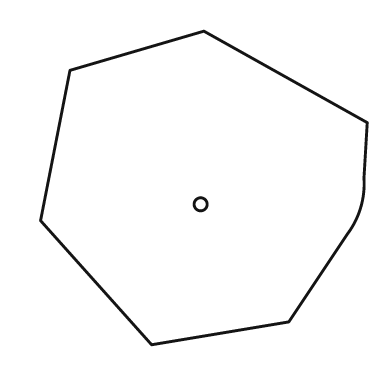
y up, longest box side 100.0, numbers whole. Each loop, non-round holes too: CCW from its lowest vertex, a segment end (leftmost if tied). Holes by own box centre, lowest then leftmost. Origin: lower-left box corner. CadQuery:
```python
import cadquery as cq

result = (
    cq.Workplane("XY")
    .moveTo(34.0, 0.0)
    .lineTo(76.0, 7.0)
    .lineTo(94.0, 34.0)
    .threePointArc((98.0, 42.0), (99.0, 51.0))
    .lineTo(100.0, 68.0)
    .lineTo(50.0, 96.0)
    .lineTo(9.0, 84.0)
    .lineTo(0.0, 38.0)
    .close()
    .moveTo(49.0, 43.0)
    .circle(2.0)
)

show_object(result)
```